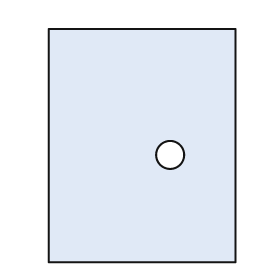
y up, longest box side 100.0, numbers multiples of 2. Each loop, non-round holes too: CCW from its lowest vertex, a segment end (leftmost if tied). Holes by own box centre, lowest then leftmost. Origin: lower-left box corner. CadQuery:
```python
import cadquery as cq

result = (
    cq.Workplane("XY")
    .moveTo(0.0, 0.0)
    .lineTo(80.0, 0.0)
    .lineTo(80.0, 100.0)
    .lineTo(0.0, 100.0)
    .close()
    .moveTo(52.0, 46.0)
    .circle(6.0)
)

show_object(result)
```